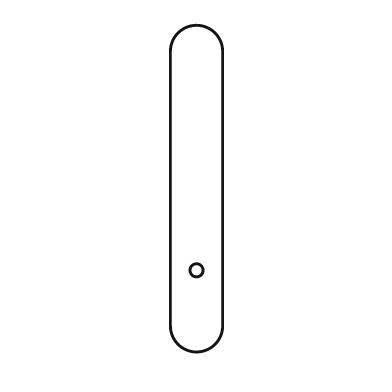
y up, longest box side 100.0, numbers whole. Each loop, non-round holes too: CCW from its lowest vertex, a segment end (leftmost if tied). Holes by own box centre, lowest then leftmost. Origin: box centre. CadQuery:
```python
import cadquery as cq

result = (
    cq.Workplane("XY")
    .moveTo(-8.0, -42.0)
    .threePointArc((0.0, -50.0), (8.0, -42.0))
    .lineTo(8.0, 42.0)
    .threePointArc((0.0, 50.0), (-8.0, 42.0))
    .close()
    .moveTo(0.0, -25.0)
    .circle(2.0)
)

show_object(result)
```